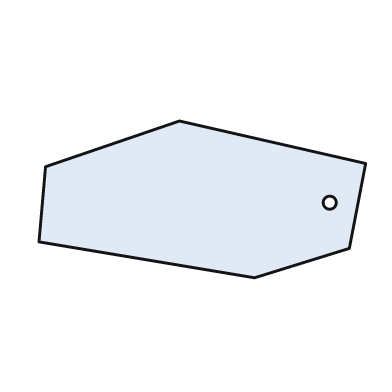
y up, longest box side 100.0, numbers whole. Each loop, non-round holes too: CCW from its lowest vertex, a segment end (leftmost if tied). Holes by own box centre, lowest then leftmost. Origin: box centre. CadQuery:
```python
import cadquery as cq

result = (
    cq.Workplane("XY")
    .moveTo(16.0, -24.0)
    .lineTo(45.0, -15.0)
    .lineTo(50.0, 11.0)
    .lineTo(-7.0, 24.0)
    .lineTo(-48.0, 10.0)
    .lineTo(-50.0, -13.0)
    .close()
    .moveTo(39.0, -1.0)
    .circle(2.0)
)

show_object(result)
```